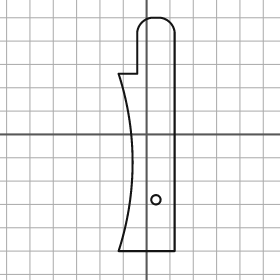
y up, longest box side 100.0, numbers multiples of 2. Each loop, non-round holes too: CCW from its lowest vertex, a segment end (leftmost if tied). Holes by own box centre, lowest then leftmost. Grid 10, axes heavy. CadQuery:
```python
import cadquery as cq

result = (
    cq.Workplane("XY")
    .moveTo(-12.0, -50.0)
    .lineTo(12.0, -50.0)
    .lineTo(12.0, 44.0)
    .threePointArc((10.0, 48.0), (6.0, 50.0))
    .lineTo(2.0, 50.0)
    .threePointArc((-2.0, 48.0), (-4.0, 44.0))
    .lineTo(-4.0, 26.0)
    .lineTo(-12.0, 26.0)
    .threePointArc((-6.0, -12.0), (-12.0, -50.0))
    .close()
    .moveTo(4.0, -28.0)
    .circle(2.0)
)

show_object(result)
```